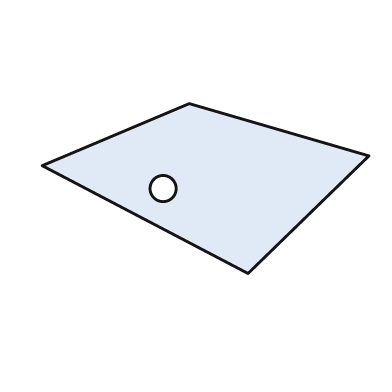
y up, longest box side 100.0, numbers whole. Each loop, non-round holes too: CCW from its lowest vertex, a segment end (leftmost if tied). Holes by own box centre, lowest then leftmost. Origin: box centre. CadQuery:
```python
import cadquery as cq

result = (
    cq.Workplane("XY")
    .moveTo(13.0, -26.0)
    .lineTo(50.0, 10.0)
    .lineTo(-5.0, 26.0)
    .lineTo(-50.0, 7.0)
    .close()
    .moveTo(-13.0, 0.0)
    .circle(4.0)
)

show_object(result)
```